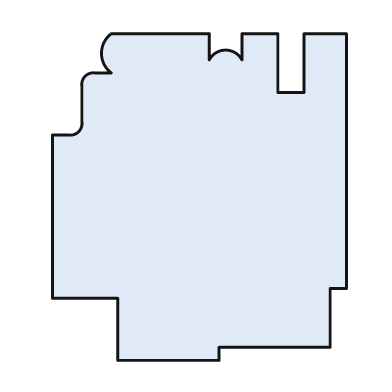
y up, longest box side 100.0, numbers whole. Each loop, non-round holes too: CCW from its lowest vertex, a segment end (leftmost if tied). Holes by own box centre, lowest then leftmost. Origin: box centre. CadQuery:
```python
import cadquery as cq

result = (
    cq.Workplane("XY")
    .moveTo(-25.0, -50.0)
    .lineTo(6.0, -50.0)
    .lineTo(6.0, -46.0)
    .lineTo(40.0, -46.0)
    .lineTo(40.0, -28.0)
    .lineTo(45.0, -28.0)
    .lineTo(45.0, 50.0)
    .lineTo(32.0, 50.0)
    .lineTo(32.0, 32.0)
    .lineTo(24.0, 32.0)
    .lineTo(24.0, 50.0)
    .lineTo(13.0, 50.0)
    .lineTo(13.0, 42.0)
    .threePointArc((8.0, 45.0), (3.0, 42.0))
    .lineTo(3.0, 50.0)
    .lineTo(-27.0, 50.0)
    .threePointArc((-30.0, 44.0), (-27.0, 38.0))
    .lineTo(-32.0, 38.0)
    .threePointArc((-35.0, 37.0), (-36.0, 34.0))
    .lineTo(-36.0, 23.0)
    .threePointArc((-37.0, 20.0), (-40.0, 19.0))
    .lineTo(-45.0, 19.0)
    .lineTo(-45.0, -31.0)
    .lineTo(-25.0, -31.0)
    .close()
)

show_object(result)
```